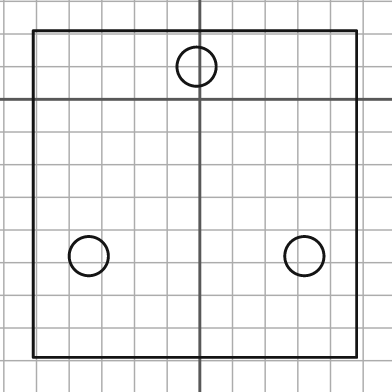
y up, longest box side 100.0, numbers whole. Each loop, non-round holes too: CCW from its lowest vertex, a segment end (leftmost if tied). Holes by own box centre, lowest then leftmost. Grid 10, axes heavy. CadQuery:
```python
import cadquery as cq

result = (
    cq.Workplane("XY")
    .moveTo(-51.0, -79.0)
    .lineTo(48.0, -79.0)
    .lineTo(48.0, 21.0)
    .lineTo(-51.0, 21.0)
    .close()
    .moveTo(-34.0, -48.0)
    .circle(6.0)
    .moveTo(32.0, -48.0)
    .circle(6.0)
    .moveTo(-1.0, 10.0)
    .circle(6.0)
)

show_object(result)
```